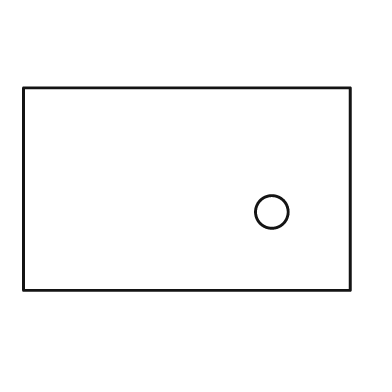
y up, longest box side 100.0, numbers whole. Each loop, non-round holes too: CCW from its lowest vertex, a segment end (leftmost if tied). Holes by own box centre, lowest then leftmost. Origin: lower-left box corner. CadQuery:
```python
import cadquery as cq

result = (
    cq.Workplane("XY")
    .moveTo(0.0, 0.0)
    .lineTo(100.0, 0.0)
    .lineTo(100.0, 62.0)
    .lineTo(0.0, 62.0)
    .close()
    .moveTo(76.0, 24.0)
    .circle(5.0)
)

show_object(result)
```